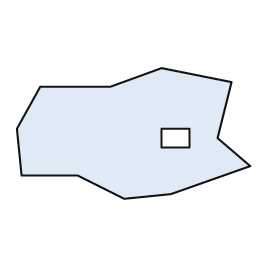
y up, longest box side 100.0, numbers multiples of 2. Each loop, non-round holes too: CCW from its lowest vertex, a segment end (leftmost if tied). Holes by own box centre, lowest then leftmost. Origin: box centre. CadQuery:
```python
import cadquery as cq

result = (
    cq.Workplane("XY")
    .moveTo(-4.0, -28.0)
    .lineTo(16.0, -26.0)
    .lineTo(50.0, -14.0)
    .lineTo(36.0, -2.0)
    .lineTo(42.0, 22.0)
    .lineTo(12.0, 28.0)
    .lineTo(-10.0, 20.0)
    .lineTo(-40.0, 20.0)
    .lineTo(-50.0, 2.0)
    .lineTo(-48.0, -18.0)
    .lineTo(-24.0, -18.0)
    .close()
    .moveTo(12.0, -6.0)
    .lineTo(24.0, -6.0)
    .lineTo(24.0, 2.0)
    .lineTo(12.0, 2.0)
    .close()
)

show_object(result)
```